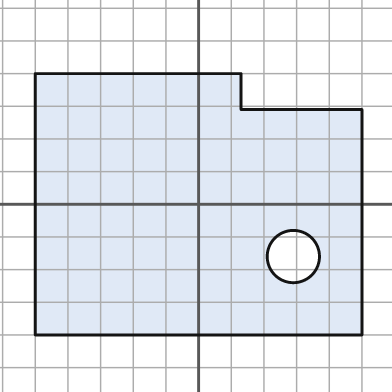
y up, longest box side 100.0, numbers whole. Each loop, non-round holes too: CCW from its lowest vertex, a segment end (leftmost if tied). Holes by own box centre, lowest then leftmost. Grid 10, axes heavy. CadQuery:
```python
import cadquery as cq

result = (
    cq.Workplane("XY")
    .moveTo(-50.0, -40.0)
    .lineTo(50.0, -40.0)
    .lineTo(50.0, 29.0)
    .lineTo(13.0, 29.0)
    .lineTo(13.0, 40.0)
    .lineTo(-50.0, 40.0)
    .close()
    .moveTo(29.0, -16.0)
    .circle(8.0)
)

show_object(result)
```